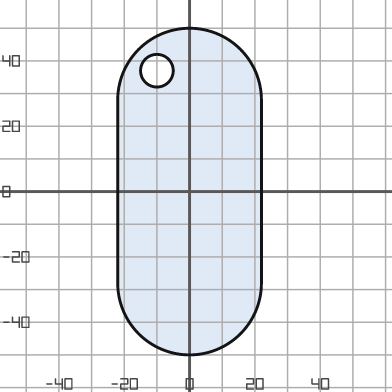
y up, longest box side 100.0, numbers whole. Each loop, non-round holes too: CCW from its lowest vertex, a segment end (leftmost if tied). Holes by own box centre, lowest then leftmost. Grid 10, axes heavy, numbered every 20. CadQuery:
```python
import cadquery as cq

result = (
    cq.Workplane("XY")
    .moveTo(-22.0, -28.0)
    .threePointArc((0.0, -50.0), (22.0, -28.0))
    .lineTo(22.0, 28.0)
    .threePointArc((0.0, 50.0), (-22.0, 28.0))
    .close()
    .moveTo(-10.0, 37.0)
    .circle(5.0)
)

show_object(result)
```